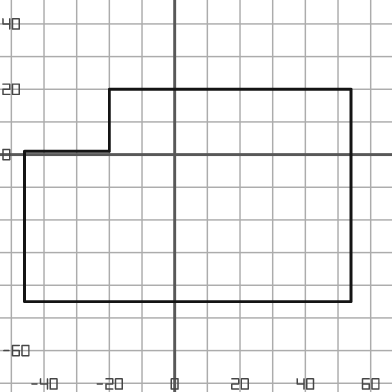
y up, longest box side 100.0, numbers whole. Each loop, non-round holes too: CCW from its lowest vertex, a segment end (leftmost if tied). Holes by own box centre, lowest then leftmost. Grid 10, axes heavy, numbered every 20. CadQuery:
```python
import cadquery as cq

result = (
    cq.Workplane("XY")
    .moveTo(-46.0, -45.0)
    .lineTo(54.0, -45.0)
    .lineTo(54.0, 20.0)
    .lineTo(-20.0, 20.0)
    .lineTo(-20.0, 1.0)
    .lineTo(-46.0, 1.0)
    .close()
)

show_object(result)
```